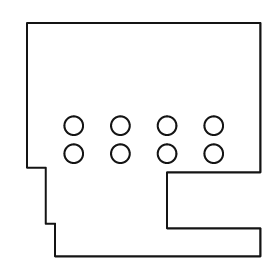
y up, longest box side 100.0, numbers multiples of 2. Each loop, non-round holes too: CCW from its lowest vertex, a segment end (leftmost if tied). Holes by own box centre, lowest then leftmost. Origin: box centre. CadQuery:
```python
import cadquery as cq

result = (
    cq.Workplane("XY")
    .moveTo(-38.0, -50.0)
    .lineTo(50.0, -50.0)
    .lineTo(50.0, -38.0)
    .lineTo(10.0, -38.0)
    .lineTo(10.0, -14.0)
    .lineTo(50.0, -14.0)
    .lineTo(50.0, 50.0)
    .lineTo(-50.0, 50.0)
    .lineTo(-50.0, -12.0)
    .lineTo(-42.0, -12.0)
    .lineTo(-42.0, -36.0)
    .lineTo(-38.0, -36.0)
    .close()
    .moveTo(-30.0, -6.0)
    .circle(4.0)
    .moveTo(-10.0, -6.0)
    .circle(4.0)
    .moveTo(10.0, -6.0)
    .circle(4.0)
    .moveTo(30.0, -6.0)
    .circle(4.0)
    .moveTo(-30.0, 6.0)
    .circle(4.0)
    .moveTo(-10.0, 6.0)
    .circle(4.0)
    .moveTo(10.0, 6.0)
    .circle(4.0)
    .moveTo(30.0, 6.0)
    .circle(4.0)
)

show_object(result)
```